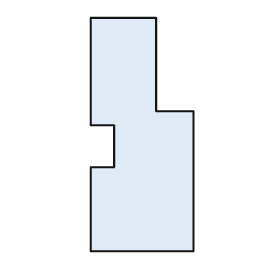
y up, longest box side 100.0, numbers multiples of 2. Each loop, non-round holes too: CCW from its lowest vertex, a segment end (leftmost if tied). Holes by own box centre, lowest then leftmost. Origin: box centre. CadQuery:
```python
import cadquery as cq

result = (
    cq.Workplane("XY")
    .moveTo(-22.0, -50.0)
    .lineTo(22.0, -50.0)
    .lineTo(22.0, 10.0)
    .lineTo(6.0, 10.0)
    .lineTo(6.0, 50.0)
    .lineTo(-22.0, 50.0)
    .lineTo(-22.0, 4.0)
    .lineTo(-12.0, 4.0)
    .lineTo(-12.0, -14.0)
    .lineTo(-22.0, -14.0)
    .close()
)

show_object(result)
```